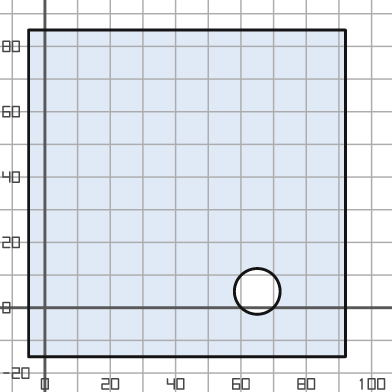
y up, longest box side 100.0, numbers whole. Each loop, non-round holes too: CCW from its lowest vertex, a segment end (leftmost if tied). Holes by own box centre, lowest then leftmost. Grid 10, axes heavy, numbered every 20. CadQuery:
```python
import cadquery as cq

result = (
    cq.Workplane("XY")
    .moveTo(-5.0, -15.0)
    .lineTo(92.0, -15.0)
    .lineTo(92.0, 85.0)
    .lineTo(-5.0, 85.0)
    .close()
    .moveTo(65.0, 5.0)
    .circle(7.0)
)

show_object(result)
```